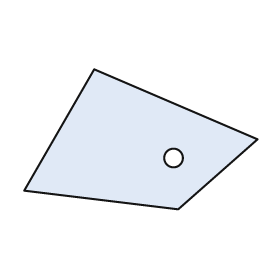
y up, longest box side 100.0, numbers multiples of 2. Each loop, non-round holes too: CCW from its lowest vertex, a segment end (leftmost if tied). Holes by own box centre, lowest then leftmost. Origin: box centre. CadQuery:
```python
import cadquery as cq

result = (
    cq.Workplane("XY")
    .moveTo(16.0, -30.0)
    .lineTo(50.0, 0.0)
    .lineTo(-20.0, 30.0)
    .lineTo(-50.0, -22.0)
    .close()
    .moveTo(14.0, -8.0)
    .circle(4.0)
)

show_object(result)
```